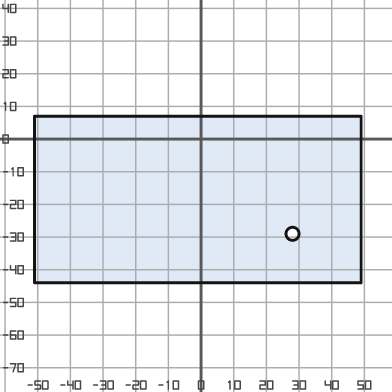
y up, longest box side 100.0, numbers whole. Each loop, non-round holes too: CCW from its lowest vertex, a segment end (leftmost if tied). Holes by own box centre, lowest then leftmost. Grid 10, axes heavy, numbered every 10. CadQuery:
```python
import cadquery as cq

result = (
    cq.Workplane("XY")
    .moveTo(-51.0, -44.0)
    .lineTo(49.0, -44.0)
    .lineTo(49.0, 7.0)
    .lineTo(-51.0, 7.0)
    .close()
    .moveTo(28.0, -29.0)
    .circle(2.0)
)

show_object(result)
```